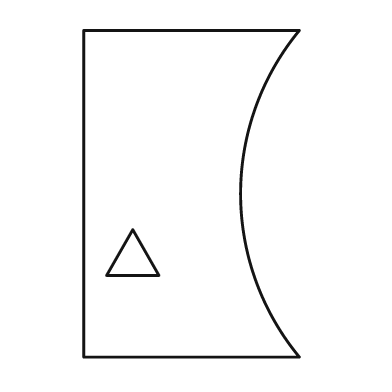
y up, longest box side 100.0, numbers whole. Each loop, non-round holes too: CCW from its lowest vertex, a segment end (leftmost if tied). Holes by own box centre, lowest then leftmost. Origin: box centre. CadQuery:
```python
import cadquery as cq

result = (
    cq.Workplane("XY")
    .moveTo(-33.0, -50.0)
    .lineTo(33.0, -50.0)
    .threePointArc((15.0, 0.0), (33.0, 50.0))
    .lineTo(-33.0, 50.0)
    .close()
    .moveTo(-26.0, -25.0)
    .lineTo(-10.0, -25.0)
    .lineTo(-18.0, -11.0)
    .close()
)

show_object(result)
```